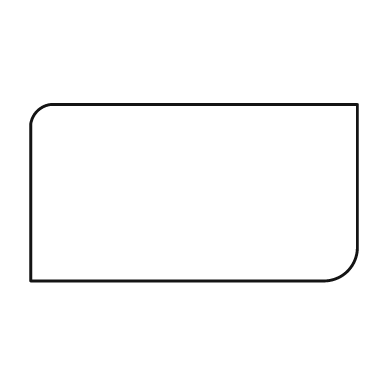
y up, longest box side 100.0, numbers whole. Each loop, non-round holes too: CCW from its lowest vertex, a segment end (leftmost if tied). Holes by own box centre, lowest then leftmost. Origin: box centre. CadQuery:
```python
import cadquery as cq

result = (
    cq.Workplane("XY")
    .moveTo(-50.0, -27.0)
    .lineTo(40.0, -27.0)
    .threePointArc((47.0, -24.0), (50.0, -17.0))
    .lineTo(50.0, 27.0)
    .lineTo(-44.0, 27.0)
    .threePointArc((-48.0, 25.0), (-50.0, 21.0))
    .close()
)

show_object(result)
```